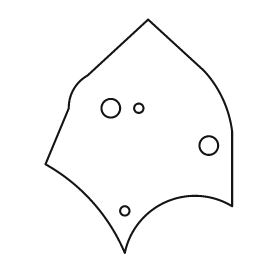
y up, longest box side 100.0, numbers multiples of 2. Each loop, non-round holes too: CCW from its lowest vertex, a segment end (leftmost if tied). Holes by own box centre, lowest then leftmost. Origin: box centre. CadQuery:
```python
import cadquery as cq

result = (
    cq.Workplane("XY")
    .moveTo(-6.0, -50.0)
    .threePointArc((12.0, -28.0), (40.0, -30.0))
    .lineTo(40.0, 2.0)
    .threePointArc((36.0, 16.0), (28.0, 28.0))
    .lineTo(4.0, 50.0)
    .lineTo(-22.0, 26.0)
    .threePointArc((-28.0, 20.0), (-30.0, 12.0))
    .lineTo(-40.0, -12.0)
    .threePointArc((-20.0, -28.0), (-6.0, -50.0))
    .close()
    .moveTo(-6.0, -32.0)
    .circle(2.0)
    .moveTo(30.0, -4.0)
    .circle(4.0)
    .moveTo(-12.0, 12.0)
    .circle(4.0)
    .moveTo(0.0, 12.0)
    .circle(2.0)
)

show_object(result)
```